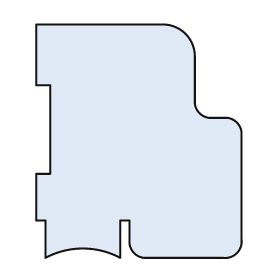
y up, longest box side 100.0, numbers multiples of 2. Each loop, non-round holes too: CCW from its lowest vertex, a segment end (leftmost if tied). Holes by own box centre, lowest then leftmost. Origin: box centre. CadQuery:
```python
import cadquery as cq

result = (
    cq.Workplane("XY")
    .moveTo(-40.0, -50.0)
    .threePointArc((-24.0, -46.0), (-8.0, -50.0))
    .lineTo(-8.0, -34.0)
    .lineTo(-4.0, -34.0)
    .lineTo(-4.0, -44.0)
    .threePointArc((-2.0, -48.0), (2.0, -50.0))
    .lineTo(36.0, -50.0)
    .threePointArc((42.0, -48.0), (44.0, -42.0))
    .lineTo(44.0, 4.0)
    .threePointArc((42.0, 8.0), (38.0, 10.0))
    .lineTo(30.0, 10.0)
    .threePointArc((26.0, 12.0), (24.0, 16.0))
    .lineTo(24.0, 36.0)
    .threePointArc((20.0, 46.0), (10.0, 50.0))
    .lineTo(-44.0, 50.0)
    .lineTo(-44.0, 24.0)
    .lineTo(-38.0, 24.0)
    .lineTo(-38.0, -14.0)
    .lineTo(-44.0, -14.0)
    .lineTo(-44.0, -34.0)
    .lineTo(-40.0, -34.0)
    .close()
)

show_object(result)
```